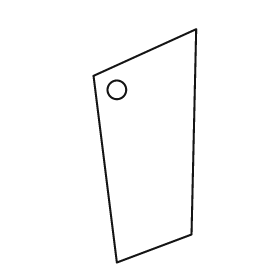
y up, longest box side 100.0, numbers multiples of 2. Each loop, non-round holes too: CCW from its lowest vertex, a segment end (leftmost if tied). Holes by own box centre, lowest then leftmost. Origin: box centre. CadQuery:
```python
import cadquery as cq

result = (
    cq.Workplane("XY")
    .moveTo(-12.0, -50.0)
    .lineTo(20.0, -38.0)
    .lineTo(22.0, 50.0)
    .lineTo(-22.0, 30.0)
    .close()
    .moveTo(-12.0, 24.0)
    .circle(4.0)
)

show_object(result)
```